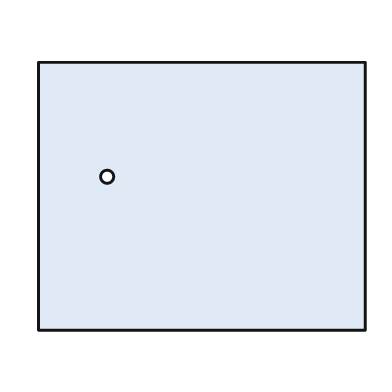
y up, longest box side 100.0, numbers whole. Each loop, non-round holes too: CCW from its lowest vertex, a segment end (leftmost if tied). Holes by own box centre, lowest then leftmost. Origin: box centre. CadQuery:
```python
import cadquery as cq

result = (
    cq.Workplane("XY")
    .moveTo(-50.0, -41.0)
    .lineTo(50.0, -41.0)
    .lineTo(50.0, 41.0)
    .lineTo(-50.0, 41.0)
    .close()
    .moveTo(-29.0, 6.0)
    .circle(2.0)
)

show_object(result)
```